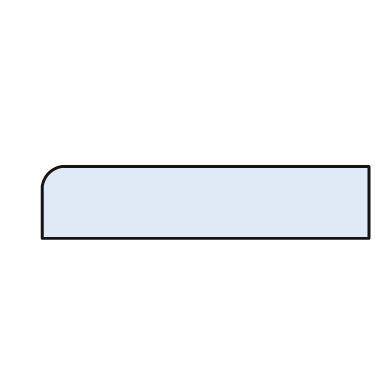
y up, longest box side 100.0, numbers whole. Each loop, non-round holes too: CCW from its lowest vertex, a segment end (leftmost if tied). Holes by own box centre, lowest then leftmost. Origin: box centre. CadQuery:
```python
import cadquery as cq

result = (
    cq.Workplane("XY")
    .moveTo(-50.0, -11.0)
    .lineTo(50.0, -11.0)
    .lineTo(50.0, 11.0)
    .lineTo(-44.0, 11.0)
    .threePointArc((-48.0, 9.0), (-50.0, 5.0))
    .close()
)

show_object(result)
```